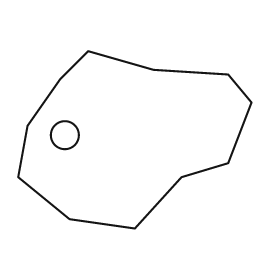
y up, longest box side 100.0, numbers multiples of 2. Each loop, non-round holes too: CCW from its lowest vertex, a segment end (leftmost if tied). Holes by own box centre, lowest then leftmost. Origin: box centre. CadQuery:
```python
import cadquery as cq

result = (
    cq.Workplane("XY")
    .moveTo(0.0, -38.0)
    .lineTo(20.0, -16.0)
    .lineTo(40.0, -10.0)
    .lineTo(50.0, 16.0)
    .lineTo(40.0, 28.0)
    .lineTo(8.0, 30.0)
    .lineTo(-20.0, 38.0)
    .lineTo(-32.0, 26.0)
    .lineTo(-46.0, 6.0)
    .lineTo(-50.0, -16.0)
    .lineTo(-28.0, -34.0)
    .close()
    .moveTo(-30.0, 2.0)
    .circle(6.0)
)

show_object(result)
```